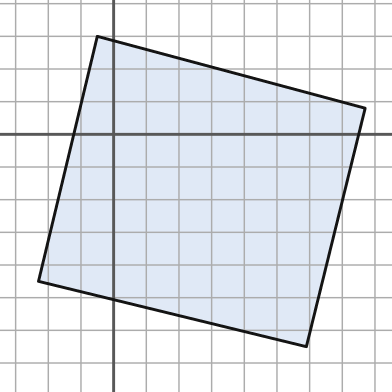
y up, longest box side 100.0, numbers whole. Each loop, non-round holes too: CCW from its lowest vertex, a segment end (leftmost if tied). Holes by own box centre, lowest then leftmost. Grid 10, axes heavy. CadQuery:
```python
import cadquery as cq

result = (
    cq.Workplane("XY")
    .moveTo(59.0, -65.0)
    .lineTo(77.0, 8.0)
    .lineTo(-5.0, 30.0)
    .lineTo(-23.0, -45.0)
    .close()
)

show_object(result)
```